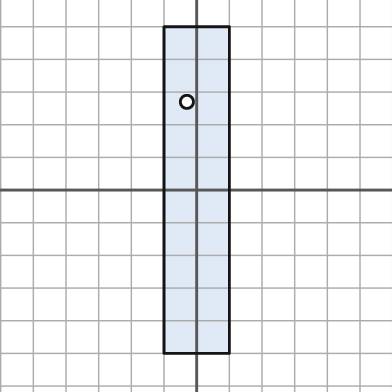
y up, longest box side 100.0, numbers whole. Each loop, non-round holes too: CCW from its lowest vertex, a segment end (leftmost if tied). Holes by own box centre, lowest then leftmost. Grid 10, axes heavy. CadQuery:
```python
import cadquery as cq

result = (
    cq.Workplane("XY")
    .moveTo(-10.0, -50.0)
    .lineTo(10.0, -50.0)
    .lineTo(10.0, 50.0)
    .lineTo(-10.0, 50.0)
    .close()
    .moveTo(-3.0, 27.0)
    .circle(2.0)
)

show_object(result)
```